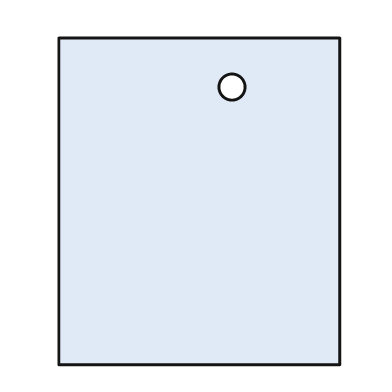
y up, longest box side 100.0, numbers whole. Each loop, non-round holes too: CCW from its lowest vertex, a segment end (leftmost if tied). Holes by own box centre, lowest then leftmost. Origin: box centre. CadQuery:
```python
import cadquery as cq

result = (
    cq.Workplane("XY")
    .moveTo(-43.0, -50.0)
    .lineTo(43.0, -50.0)
    .lineTo(43.0, 50.0)
    .lineTo(-43.0, 50.0)
    .close()
    .moveTo(10.0, 35.0)
    .circle(4.0)
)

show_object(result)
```